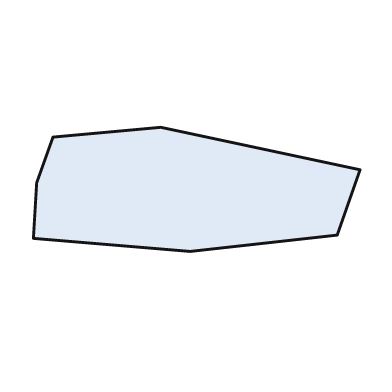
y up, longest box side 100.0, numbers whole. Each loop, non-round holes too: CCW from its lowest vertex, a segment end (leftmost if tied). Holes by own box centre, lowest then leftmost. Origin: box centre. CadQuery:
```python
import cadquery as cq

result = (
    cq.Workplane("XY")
    .moveTo(-2.0, -19.0)
    .lineTo(43.0, -14.0)
    .lineTo(50.0, 6.0)
    .lineTo(-11.0, 19.0)
    .lineTo(-44.0, 16.0)
    .lineTo(-49.0, 2.0)
    .lineTo(-50.0, -15.0)
    .close()
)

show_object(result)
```